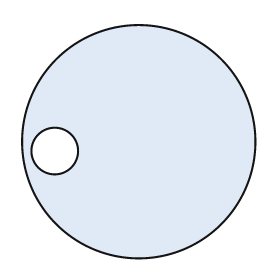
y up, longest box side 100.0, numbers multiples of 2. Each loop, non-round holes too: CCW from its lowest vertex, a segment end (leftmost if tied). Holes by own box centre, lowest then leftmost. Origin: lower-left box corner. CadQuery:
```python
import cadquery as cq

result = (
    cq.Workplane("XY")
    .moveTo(50.0, 50.0)
    .circle(50.0)
    .moveTo(14.0, 46.0)
    .circle(10.0)
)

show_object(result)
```